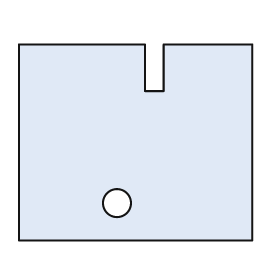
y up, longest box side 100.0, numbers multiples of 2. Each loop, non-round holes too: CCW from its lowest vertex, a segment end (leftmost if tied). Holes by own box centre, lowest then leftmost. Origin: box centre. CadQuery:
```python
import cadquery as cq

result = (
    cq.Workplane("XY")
    .moveTo(-50.0, -42.0)
    .lineTo(50.0, -42.0)
    .lineTo(50.0, 42.0)
    .lineTo(12.0, 42.0)
    .lineTo(12.0, 22.0)
    .lineTo(4.0, 22.0)
    .lineTo(4.0, 42.0)
    .lineTo(-50.0, 42.0)
    .close()
    .moveTo(-8.0, -26.0)
    .circle(6.0)
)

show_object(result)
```